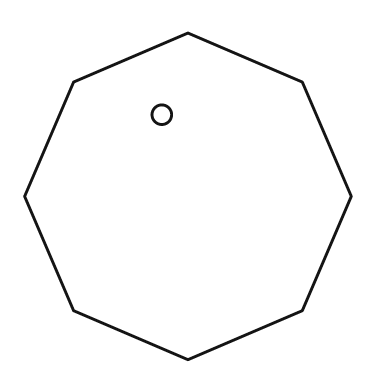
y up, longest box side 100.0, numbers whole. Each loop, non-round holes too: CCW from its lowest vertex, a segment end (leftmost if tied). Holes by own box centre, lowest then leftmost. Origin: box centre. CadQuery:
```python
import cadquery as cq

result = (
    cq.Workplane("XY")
    .moveTo(0.0, -50.0)
    .lineTo(35.0, -35.0)
    .lineTo(50.0, 0.0)
    .lineTo(35.0, 35.0)
    .lineTo(0.0, 50.0)
    .lineTo(-35.0, 35.0)
    .lineTo(-50.0, 0.0)
    .lineTo(-35.0, -35.0)
    .close()
    .moveTo(-8.0, 25.0)
    .circle(3.0)
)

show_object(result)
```